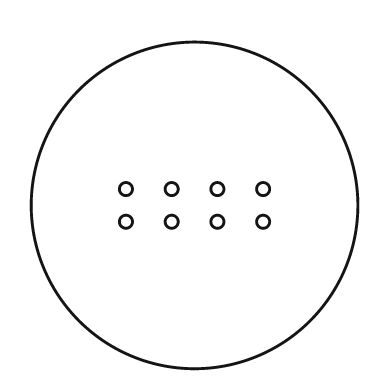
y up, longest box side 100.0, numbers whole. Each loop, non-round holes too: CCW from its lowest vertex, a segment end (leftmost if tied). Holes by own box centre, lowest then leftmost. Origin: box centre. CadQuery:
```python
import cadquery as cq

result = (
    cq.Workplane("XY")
    .moveTo(0.0, 0.0)
    .circle(50.0)
    .moveTo(-21.0, -5.0)
    .circle(2.0)
    .moveTo(-7.0, -5.0)
    .circle(2.0)
    .moveTo(7.0, -5.0)
    .circle(2.0)
    .moveTo(21.0, -5.0)
    .circle(2.0)
    .moveTo(-21.0, 5.0)
    .circle(2.0)
    .moveTo(-7.0, 5.0)
    .circle(2.0)
    .moveTo(7.0, 5.0)
    .circle(2.0)
    .moveTo(21.0, 5.0)
    .circle(2.0)
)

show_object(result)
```